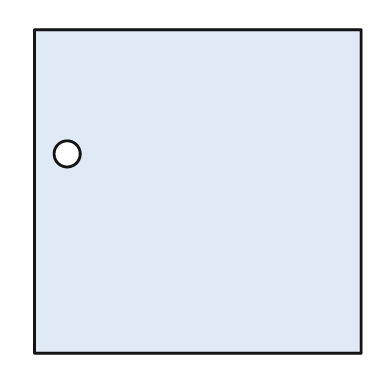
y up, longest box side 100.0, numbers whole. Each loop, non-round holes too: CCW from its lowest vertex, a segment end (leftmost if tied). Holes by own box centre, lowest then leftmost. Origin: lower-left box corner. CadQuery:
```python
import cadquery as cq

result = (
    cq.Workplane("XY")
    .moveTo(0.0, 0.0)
    .lineTo(100.0, 0.0)
    .lineTo(100.0, 99.0)
    .lineTo(0.0, 99.0)
    .close()
    .moveTo(10.0, 61.0)
    .circle(4.0)
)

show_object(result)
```